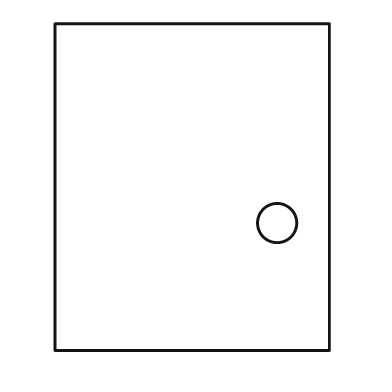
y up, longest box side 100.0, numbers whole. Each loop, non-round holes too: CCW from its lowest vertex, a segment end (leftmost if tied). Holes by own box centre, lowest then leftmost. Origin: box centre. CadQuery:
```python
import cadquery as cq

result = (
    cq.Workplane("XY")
    .moveTo(-42.0, -50.0)
    .lineTo(42.0, -50.0)
    .lineTo(42.0, 50.0)
    .lineTo(-42.0, 50.0)
    .close()
    .moveTo(26.0, -11.0)
    .circle(6.0)
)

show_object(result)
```